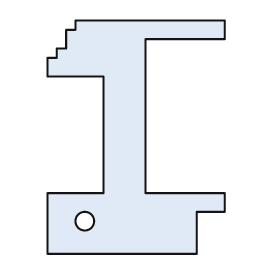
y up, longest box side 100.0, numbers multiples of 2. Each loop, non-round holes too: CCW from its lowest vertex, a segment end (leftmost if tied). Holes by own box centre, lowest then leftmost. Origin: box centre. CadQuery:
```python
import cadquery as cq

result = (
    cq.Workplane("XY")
    .moveTo(-38.0, -50.0)
    .lineTo(26.0, -50.0)
    .lineTo(26.0, -32.0)
    .lineTo(38.0, -32.0)
    .lineTo(38.0, -24.0)
    .lineTo(4.0, -24.0)
    .lineTo(4.0, 42.0)
    .lineTo(38.0, 42.0)
    .lineTo(38.0, 50.0)
    .lineTo(-26.0, 50.0)
    .lineTo(-26.0, 46.0)
    .lineTo(-30.0, 46.0)
    .lineTo(-30.0, 38.0)
    .lineTo(-34.0, 38.0)
    .lineTo(-34.0, 34.0)
    .lineTo(-38.0, 34.0)
    .lineTo(-38.0, 26.0)
    .lineTo(-14.0, 26.0)
    .lineTo(-14.0, -24.0)
    .lineTo(-38.0, -24.0)
    .close()
    .moveTo(-22.0, -36.0)
    .circle(4.0)
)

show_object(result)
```